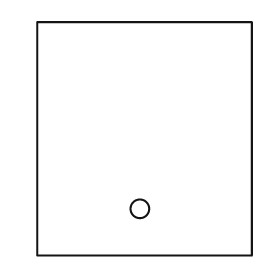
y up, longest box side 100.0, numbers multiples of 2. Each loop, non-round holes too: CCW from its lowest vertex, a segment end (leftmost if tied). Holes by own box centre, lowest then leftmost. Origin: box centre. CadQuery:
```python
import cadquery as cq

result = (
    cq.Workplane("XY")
    .moveTo(-46.0, -50.0)
    .lineTo(46.0, -50.0)
    .lineTo(46.0, 50.0)
    .lineTo(-46.0, 50.0)
    .close()
    .moveTo(-2.0, -30.0)
    .circle(4.0)
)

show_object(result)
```